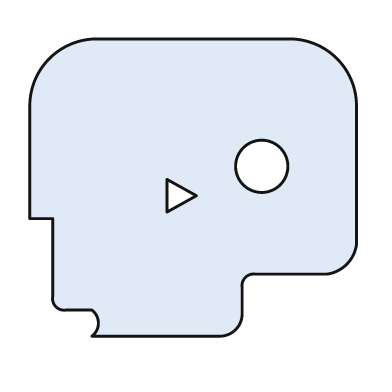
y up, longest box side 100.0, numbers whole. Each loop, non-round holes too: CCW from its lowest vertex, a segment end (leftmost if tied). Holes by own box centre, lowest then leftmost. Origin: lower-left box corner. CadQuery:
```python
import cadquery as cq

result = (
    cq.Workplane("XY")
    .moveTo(19.0, 0.0)
    .lineTo(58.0, 0.0)
    .threePointArc((63.0, 2.0), (65.0, 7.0))
    .lineTo(65.0, 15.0)
    .threePointArc((66.0, 18.0), (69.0, 19.0))
    .lineTo(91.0, 19.0)
    .threePointArc((97.0, 22.0), (100.0, 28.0))
    .lineTo(100.0, 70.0)
    .threePointArc((94.0, 85.0), (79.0, 91.0))
    .lineTo(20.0, 91.0)
    .threePointArc((6.0, 85.0), (0.0, 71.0))
    .lineTo(0.0, 36.0)
    .lineTo(7.0, 36.0)
    .lineTo(7.0, 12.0)
    .threePointArc((8.0, 9.0), (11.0, 8.0))
    .lineTo(19.0, 8.0)
    .threePointArc((21.0, 4.0), (19.0, 0.0))
    .close()
    .moveTo(42.0, 38.0)
    .lineTo(51.0, 43.0)
    .lineTo(42.0, 48.0)
    .close()
    .moveTo(71.0, 52.0)
    .circle(8.0)
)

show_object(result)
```